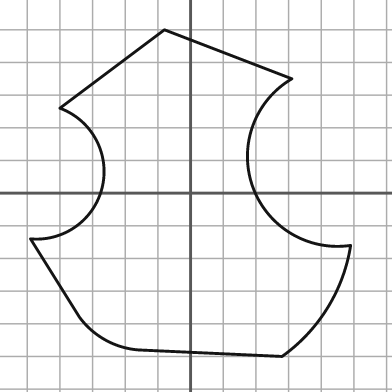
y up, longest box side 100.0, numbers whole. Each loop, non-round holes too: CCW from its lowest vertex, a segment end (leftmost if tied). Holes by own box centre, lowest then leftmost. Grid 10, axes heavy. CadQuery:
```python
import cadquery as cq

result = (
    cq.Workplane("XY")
    .moveTo(28.0, -50.0)
    .threePointArc((42.0, -35.0), (49.0, -16.0))
    .threePointArc((19.0, 2.0), (31.0, 35.0))
    .lineTo(-8.0, 50.0)
    .lineTo(-40.0, 26.0)
    .threePointArc((-27.0, 2.0), (-49.0, -14.0))
    .lineTo(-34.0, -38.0)
    .threePointArc((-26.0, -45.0), (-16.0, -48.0))
    .close()
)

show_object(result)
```